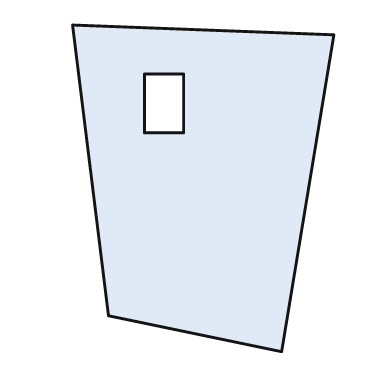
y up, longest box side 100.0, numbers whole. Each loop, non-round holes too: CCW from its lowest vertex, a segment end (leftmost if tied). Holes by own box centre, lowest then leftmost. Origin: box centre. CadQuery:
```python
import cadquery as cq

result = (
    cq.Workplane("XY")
    .moveTo(24.0, -50.0)
    .lineTo(40.0, 47.0)
    .lineTo(-40.0, 50.0)
    .lineTo(-29.0, -39.0)
    .close()
    .moveTo(-18.0, 17.0)
    .lineTo(-6.0, 17.0)
    .lineTo(-6.0, 35.0)
    .lineTo(-18.0, 35.0)
    .close()
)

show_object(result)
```